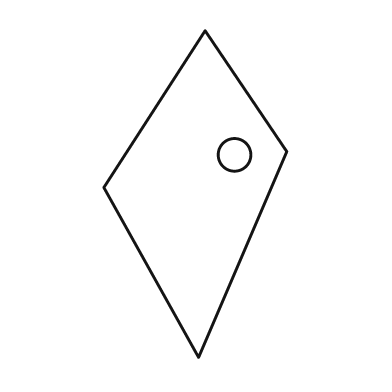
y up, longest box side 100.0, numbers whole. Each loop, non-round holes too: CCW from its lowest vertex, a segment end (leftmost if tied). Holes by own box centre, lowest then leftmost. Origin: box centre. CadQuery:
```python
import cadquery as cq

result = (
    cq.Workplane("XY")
    .moveTo(1.0, -50.0)
    .lineTo(28.0, 13.0)
    .lineTo(3.0, 50.0)
    .lineTo(-28.0, 2.0)
    .close()
    .moveTo(12.0, 12.0)
    .circle(5.0)
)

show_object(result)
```